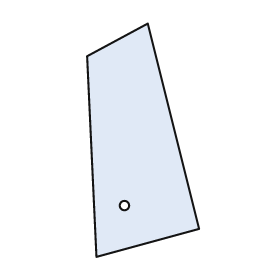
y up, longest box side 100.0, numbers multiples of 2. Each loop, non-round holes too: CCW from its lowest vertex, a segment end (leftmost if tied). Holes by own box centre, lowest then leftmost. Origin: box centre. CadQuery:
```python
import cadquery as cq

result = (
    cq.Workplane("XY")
    .moveTo(-20.0, -50.0)
    .lineTo(24.0, -38.0)
    .lineTo(2.0, 50.0)
    .lineTo(-24.0, 36.0)
    .close()
    .moveTo(-8.0, -28.0)
    .circle(2.0)
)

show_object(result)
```